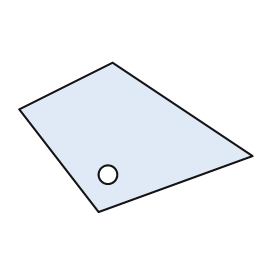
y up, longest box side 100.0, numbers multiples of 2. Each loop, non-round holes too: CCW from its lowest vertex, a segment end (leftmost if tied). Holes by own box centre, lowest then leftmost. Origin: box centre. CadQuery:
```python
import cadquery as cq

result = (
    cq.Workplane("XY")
    .moveTo(-16.0, -32.0)
    .lineTo(50.0, -8.0)
    .lineTo(-10.0, 32.0)
    .lineTo(-50.0, 12.0)
    .close()
    .moveTo(-12.0, -16.0)
    .circle(4.0)
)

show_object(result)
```